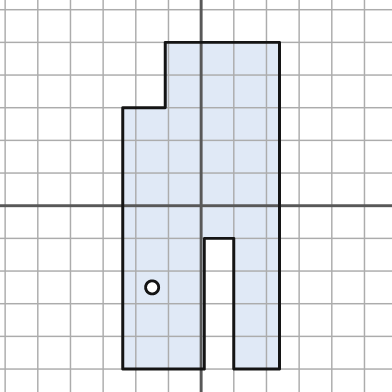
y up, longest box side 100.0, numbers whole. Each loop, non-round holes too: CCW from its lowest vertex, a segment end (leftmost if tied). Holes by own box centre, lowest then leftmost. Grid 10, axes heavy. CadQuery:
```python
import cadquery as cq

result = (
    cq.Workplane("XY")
    .moveTo(-24.0, -50.0)
    .lineTo(1.0, -50.0)
    .lineTo(1.0, -10.0)
    .lineTo(10.0, -10.0)
    .lineTo(10.0, -50.0)
    .lineTo(24.0, -50.0)
    .lineTo(24.0, 50.0)
    .lineTo(-11.0, 50.0)
    .lineTo(-11.0, 30.0)
    .lineTo(-24.0, 30.0)
    .close()
    .moveTo(-15.0, -25.0)
    .circle(2.0)
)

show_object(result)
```